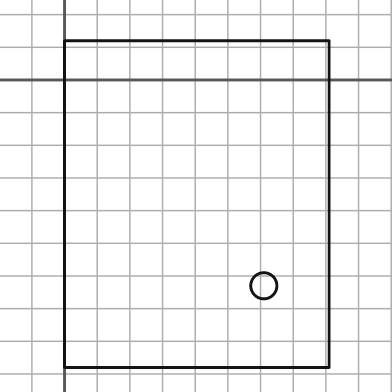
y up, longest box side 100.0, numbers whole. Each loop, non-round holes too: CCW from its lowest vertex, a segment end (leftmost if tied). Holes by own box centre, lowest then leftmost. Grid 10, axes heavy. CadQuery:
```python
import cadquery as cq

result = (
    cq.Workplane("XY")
    .moveTo(0.0, -88.0)
    .lineTo(81.0, -88.0)
    .lineTo(81.0, 12.0)
    .lineTo(0.0, 12.0)
    .close()
    .moveTo(61.0, -63.0)
    .circle(4.0)
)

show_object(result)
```